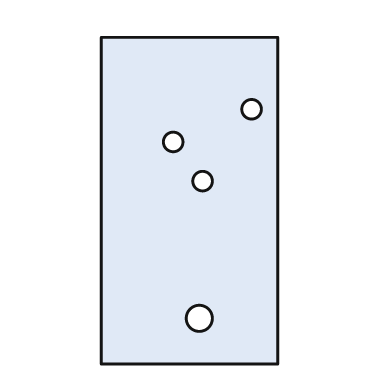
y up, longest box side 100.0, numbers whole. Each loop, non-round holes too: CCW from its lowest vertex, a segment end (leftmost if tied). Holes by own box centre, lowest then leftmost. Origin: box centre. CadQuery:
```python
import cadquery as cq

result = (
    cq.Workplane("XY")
    .moveTo(-27.0, -50.0)
    .lineTo(27.0, -50.0)
    .lineTo(27.0, 50.0)
    .lineTo(-27.0, 50.0)
    .close()
    .moveTo(3.0, -36.0)
    .circle(4.0)
    .moveTo(4.0, 6.0)
    .circle(3.0)
    .moveTo(-5.0, 18.0)
    .circle(3.0)
    .moveTo(19.0, 28.0)
    .circle(3.0)
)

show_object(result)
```